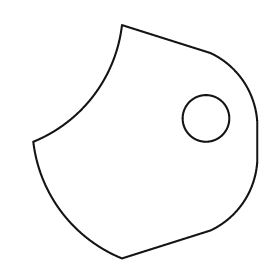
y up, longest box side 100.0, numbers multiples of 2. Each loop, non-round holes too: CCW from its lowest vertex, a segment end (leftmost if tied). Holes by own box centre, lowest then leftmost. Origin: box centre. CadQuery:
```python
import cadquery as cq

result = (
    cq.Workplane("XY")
    .moveTo(-10.0, -50.0)
    .lineTo(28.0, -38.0)
    .threePointArc((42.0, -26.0), (48.0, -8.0))
    .lineTo(48.0, 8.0)
    .threePointArc((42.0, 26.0), (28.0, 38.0))
    .lineTo(-10.0, 50.0)
    .threePointArc((-22.0, 20.0), (-48.0, 0.0))
    .threePointArc((-36.0, -30.0), (-10.0, -50.0))
    .close()
    .moveTo(26.0, 10.0)
    .circle(10.0)
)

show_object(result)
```